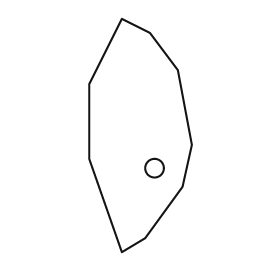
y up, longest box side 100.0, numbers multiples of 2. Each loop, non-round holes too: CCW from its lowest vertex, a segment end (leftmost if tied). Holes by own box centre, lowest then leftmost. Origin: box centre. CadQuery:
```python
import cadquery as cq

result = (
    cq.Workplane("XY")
    .moveTo(-8.0, -50.0)
    .lineTo(2.0, -44.0)
    .lineTo(18.0, -22.0)
    .lineTo(22.0, -4.0)
    .lineTo(16.0, 28.0)
    .lineTo(4.0, 44.0)
    .lineTo(-8.0, 50.0)
    .lineTo(-22.0, 22.0)
    .lineTo(-22.0, -10.0)
    .close()
    .moveTo(6.0, -14.0)
    .circle(4.0)
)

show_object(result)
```